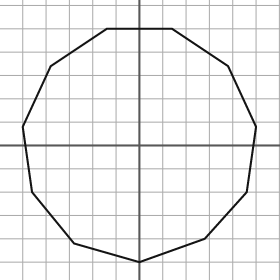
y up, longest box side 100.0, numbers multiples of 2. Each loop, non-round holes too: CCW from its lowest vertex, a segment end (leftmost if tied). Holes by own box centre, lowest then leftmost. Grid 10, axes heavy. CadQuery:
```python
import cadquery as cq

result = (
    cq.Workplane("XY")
    .moveTo(0.0, -50.0)
    .lineTo(28.0, -40.0)
    .lineTo(46.0, -20.0)
    .lineTo(50.0, 8.0)
    .lineTo(38.0, 34.0)
    .lineTo(14.0, 50.0)
    .lineTo(-14.0, 50.0)
    .lineTo(-38.0, 34.0)
    .lineTo(-50.0, 8.0)
    .lineTo(-46.0, -20.0)
    .lineTo(-28.0, -42.0)
    .close()
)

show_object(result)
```